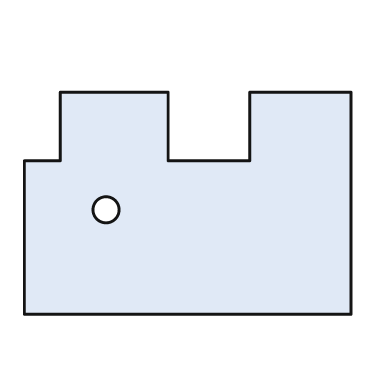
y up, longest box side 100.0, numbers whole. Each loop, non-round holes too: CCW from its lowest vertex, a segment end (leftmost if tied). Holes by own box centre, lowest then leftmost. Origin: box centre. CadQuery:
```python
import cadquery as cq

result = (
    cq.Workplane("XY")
    .moveTo(-50.0, -34.0)
    .lineTo(50.0, -34.0)
    .lineTo(50.0, 34.0)
    .lineTo(19.0, 34.0)
    .lineTo(19.0, 13.0)
    .lineTo(-6.0, 13.0)
    .lineTo(-6.0, 34.0)
    .lineTo(-39.0, 34.0)
    .lineTo(-39.0, 13.0)
    .lineTo(-50.0, 13.0)
    .close()
    .moveTo(-25.0, -2.0)
    .circle(4.0)
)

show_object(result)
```